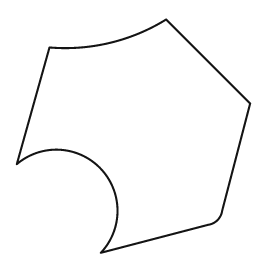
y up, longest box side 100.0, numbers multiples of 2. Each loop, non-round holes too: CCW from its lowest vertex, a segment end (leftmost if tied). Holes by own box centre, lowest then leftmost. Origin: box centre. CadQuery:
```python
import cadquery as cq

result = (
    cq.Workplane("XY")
    .moveTo(-14.0, -50.0)
    .lineTo(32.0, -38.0)
    .threePointArc((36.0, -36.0), (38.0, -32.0))
    .lineTo(50.0, 14.0)
    .lineTo(14.0, 50.0)
    .threePointArc((-10.0, 40.0), (-36.0, 38.0))
    .lineTo(-50.0, -12.0)
    .threePointArc((-14.0, -14.0), (-14.0, -50.0))
    .close()
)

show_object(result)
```